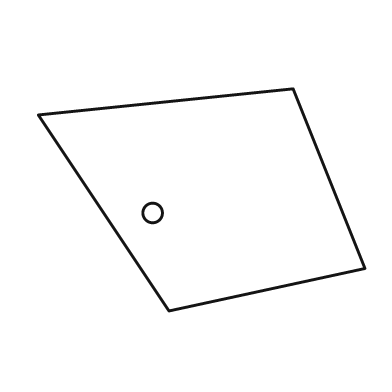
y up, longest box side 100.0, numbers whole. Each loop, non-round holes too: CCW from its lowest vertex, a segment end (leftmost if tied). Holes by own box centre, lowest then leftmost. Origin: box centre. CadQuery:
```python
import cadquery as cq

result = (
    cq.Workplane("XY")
    .moveTo(-10.0, -34.0)
    .lineTo(50.0, -21.0)
    .lineTo(28.0, 34.0)
    .lineTo(-50.0, 26.0)
    .close()
    .moveTo(-15.0, -4.0)
    .circle(3.0)
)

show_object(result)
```